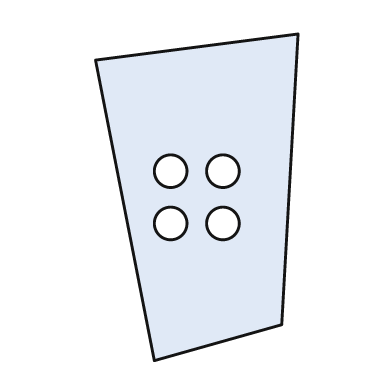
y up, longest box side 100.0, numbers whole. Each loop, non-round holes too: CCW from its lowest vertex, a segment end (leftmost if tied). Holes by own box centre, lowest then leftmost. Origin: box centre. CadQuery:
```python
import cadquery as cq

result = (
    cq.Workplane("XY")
    .moveTo(-13.0, -50.0)
    .lineTo(26.0, -39.0)
    .lineTo(31.0, 50.0)
    .lineTo(-31.0, 42.0)
    .close()
    .moveTo(-8.0, -8.0)
    .circle(5.0)
    .moveTo(8.0, -8.0)
    .circle(5.0)
    .moveTo(-8.0, 8.0)
    .circle(5.0)
    .moveTo(8.0, 8.0)
    .circle(5.0)
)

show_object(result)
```